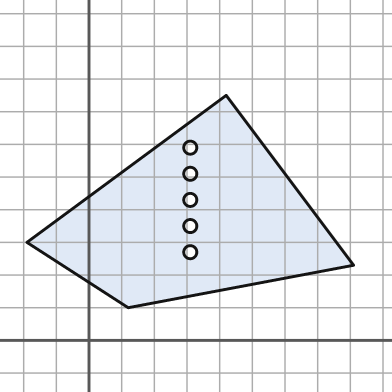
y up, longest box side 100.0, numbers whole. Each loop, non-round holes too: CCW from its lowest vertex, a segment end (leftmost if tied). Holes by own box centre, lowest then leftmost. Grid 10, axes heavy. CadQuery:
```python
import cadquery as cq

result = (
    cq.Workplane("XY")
    .moveTo(12.0, 10.0)
    .lineTo(81.0, 23.0)
    .lineTo(42.0, 75.0)
    .lineTo(-19.0, 30.0)
    .close()
    .moveTo(31.0, 27.0)
    .circle(2.0)
    .moveTo(31.0, 35.0)
    .circle(2.0)
    .moveTo(31.0, 43.0)
    .circle(2.0)
    .moveTo(31.0, 51.0)
    .circle(2.0)
    .moveTo(31.0, 59.0)
    .circle(2.0)
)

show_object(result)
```